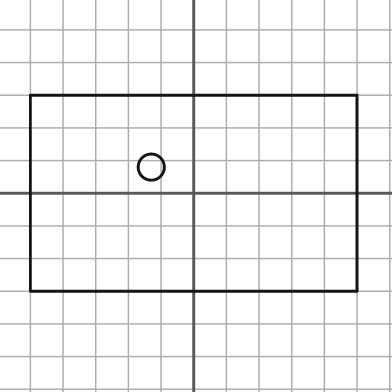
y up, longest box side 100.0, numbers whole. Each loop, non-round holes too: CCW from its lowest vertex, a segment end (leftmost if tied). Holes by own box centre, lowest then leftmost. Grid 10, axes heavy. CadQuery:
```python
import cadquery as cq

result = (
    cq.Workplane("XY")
    .moveTo(-50.0, -30.0)
    .lineTo(50.0, -30.0)
    .lineTo(50.0, 30.0)
    .lineTo(-50.0, 30.0)
    .close()
    .moveTo(-13.0, 8.0)
    .circle(4.0)
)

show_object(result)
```